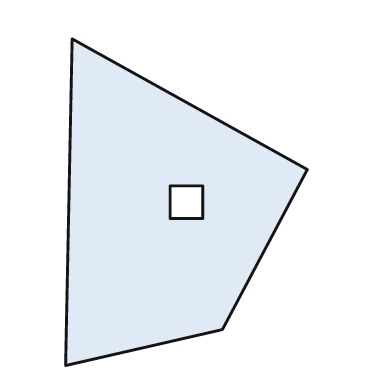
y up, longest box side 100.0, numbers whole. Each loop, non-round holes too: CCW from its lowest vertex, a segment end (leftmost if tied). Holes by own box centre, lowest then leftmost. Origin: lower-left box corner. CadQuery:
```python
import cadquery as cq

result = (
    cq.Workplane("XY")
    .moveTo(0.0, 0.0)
    .lineTo(48.0, 11.0)
    .lineTo(74.0, 60.0)
    .lineTo(2.0, 100.0)
    .close()
    .moveTo(32.0, 45.0)
    .lineTo(42.0, 45.0)
    .lineTo(42.0, 55.0)
    .lineTo(32.0, 55.0)
    .close()
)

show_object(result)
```